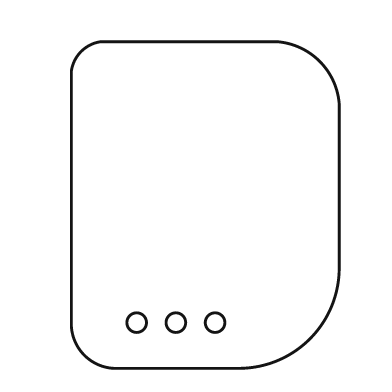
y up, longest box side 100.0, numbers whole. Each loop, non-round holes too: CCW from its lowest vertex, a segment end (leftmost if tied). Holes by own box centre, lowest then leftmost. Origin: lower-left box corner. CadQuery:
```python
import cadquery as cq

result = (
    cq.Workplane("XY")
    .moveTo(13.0, 0.0)
    .lineTo(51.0, 0.0)
    .threePointArc((73.0, 9.0), (82.0, 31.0))
    .lineTo(82.0, 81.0)
    .threePointArc((76.0, 94.0), (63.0, 100.0))
    .lineTo(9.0, 100.0)
    .threePointArc((3.0, 97.0), (0.0, 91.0))
    .lineTo(0.0, 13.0)
    .threePointArc((4.0, 4.0), (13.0, 0.0))
    .close()
    .moveTo(20.0, 14.0)
    .circle(3.0)
    .moveTo(32.0, 14.0)
    .circle(3.0)
    .moveTo(44.0, 14.0)
    .circle(3.0)
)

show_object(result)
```